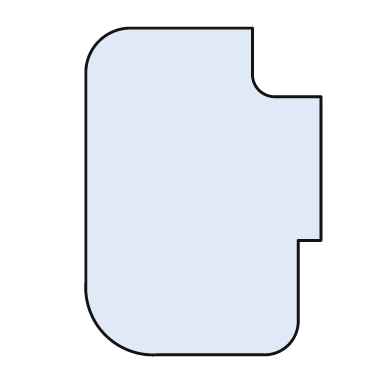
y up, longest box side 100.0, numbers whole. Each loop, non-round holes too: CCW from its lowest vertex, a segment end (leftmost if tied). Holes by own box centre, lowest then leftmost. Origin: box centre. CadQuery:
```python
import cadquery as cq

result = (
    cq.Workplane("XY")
    .moveTo(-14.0, -50.0)
    .lineTo(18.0, -50.0)
    .threePointArc((26.0, -47.0), (29.0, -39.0))
    .lineTo(29.0, -15.0)
    .lineTo(36.0, -15.0)
    .lineTo(36.0, 29.0)
    .lineTo(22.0, 29.0)
    .threePointArc((17.0, 31.0), (15.0, 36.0))
    .lineTo(15.0, 50.0)
    .lineTo(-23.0, 50.0)
    .threePointArc((-32.0, 46.0), (-36.0, 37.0))
    .lineTo(-36.0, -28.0)
    .threePointArc((-30.0, -44.0), (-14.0, -50.0))
    .close()
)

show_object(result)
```